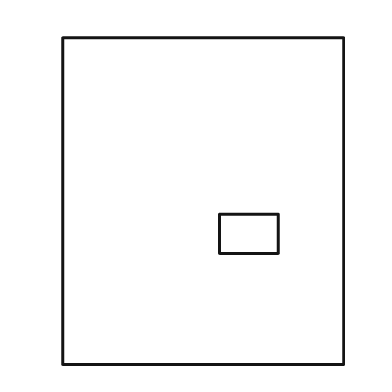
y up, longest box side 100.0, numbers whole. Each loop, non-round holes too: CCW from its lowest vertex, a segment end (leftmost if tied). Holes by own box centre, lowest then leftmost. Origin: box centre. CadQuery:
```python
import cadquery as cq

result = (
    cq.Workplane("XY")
    .moveTo(-43.0, -50.0)
    .lineTo(43.0, -50.0)
    .lineTo(43.0, 50.0)
    .lineTo(-43.0, 50.0)
    .close()
    .moveTo(5.0, -16.0)
    .lineTo(23.0, -16.0)
    .lineTo(23.0, -4.0)
    .lineTo(5.0, -4.0)
    .close()
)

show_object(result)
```